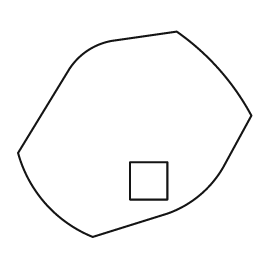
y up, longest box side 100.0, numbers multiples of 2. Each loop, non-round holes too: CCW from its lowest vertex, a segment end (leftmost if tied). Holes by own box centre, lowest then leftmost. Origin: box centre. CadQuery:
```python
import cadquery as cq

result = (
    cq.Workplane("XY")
    .moveTo(-18.0, -44.0)
    .lineTo(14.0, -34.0)
    .threePointArc((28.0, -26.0), (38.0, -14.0))
    .lineTo(50.0, 8.0)
    .threePointArc((36.0, 28.0), (18.0, 44.0))
    .lineTo(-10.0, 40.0)
    .threePointArc((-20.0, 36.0), (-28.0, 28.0))
    .lineTo(-50.0, -8.0)
    .threePointArc((-38.0, -30.0), (-18.0, -44.0))
    .close()
    .moveTo(-2.0, -28.0)
    .lineTo(14.0, -28.0)
    .lineTo(14.0, -12.0)
    .lineTo(-2.0, -12.0)
    .close()
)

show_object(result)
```